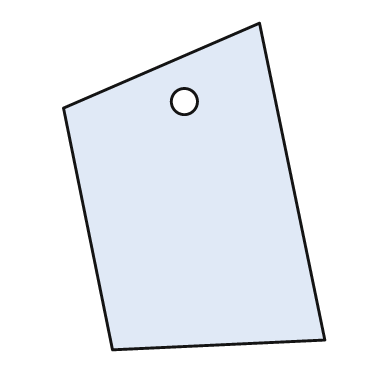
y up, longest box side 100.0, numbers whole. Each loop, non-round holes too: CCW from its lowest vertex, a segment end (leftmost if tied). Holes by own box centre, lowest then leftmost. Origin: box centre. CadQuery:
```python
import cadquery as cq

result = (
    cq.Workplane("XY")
    .moveTo(-25.0, -50.0)
    .lineTo(40.0, -47.0)
    .lineTo(20.0, 50.0)
    .lineTo(-40.0, 24.0)
    .close()
    .moveTo(-3.0, 26.0)
    .circle(4.0)
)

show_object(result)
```